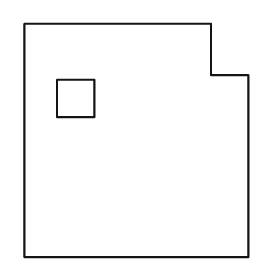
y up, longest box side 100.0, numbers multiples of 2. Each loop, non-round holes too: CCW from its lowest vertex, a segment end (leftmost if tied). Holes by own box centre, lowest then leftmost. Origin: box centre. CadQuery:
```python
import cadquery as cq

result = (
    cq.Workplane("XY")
    .moveTo(-48.0, -50.0)
    .lineTo(48.0, -50.0)
    .lineTo(48.0, 28.0)
    .lineTo(32.0, 28.0)
    .lineTo(32.0, 50.0)
    .lineTo(-48.0, 50.0)
    .close()
    .moveTo(-34.0, 10.0)
    .lineTo(-18.0, 10.0)
    .lineTo(-18.0, 26.0)
    .lineTo(-34.0, 26.0)
    .close()
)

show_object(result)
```